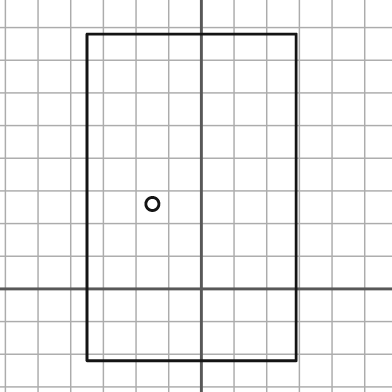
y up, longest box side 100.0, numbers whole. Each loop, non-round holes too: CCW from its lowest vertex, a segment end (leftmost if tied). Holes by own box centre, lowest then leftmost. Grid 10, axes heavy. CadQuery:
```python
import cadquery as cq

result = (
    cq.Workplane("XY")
    .moveTo(-35.0, -22.0)
    .lineTo(29.0, -22.0)
    .lineTo(29.0, 78.0)
    .lineTo(-35.0, 78.0)
    .close()
    .moveTo(-15.0, 26.0)
    .circle(2.0)
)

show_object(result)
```